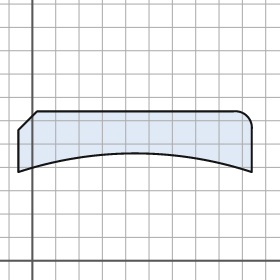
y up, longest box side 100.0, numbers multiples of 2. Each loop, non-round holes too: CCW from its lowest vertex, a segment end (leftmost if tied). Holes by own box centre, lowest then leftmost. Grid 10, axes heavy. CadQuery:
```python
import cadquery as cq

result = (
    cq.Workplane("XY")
    .moveTo(-6.0, 38.0)
    .threePointArc((44.0, 46.0), (94.0, 38.0))
    .lineTo(94.0, 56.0)
    .threePointArc((92.0, 62.0), (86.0, 64.0))
    .lineTo(2.0, 64.0)
    .lineTo(-6.0, 56.0)
    .close()
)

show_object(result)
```